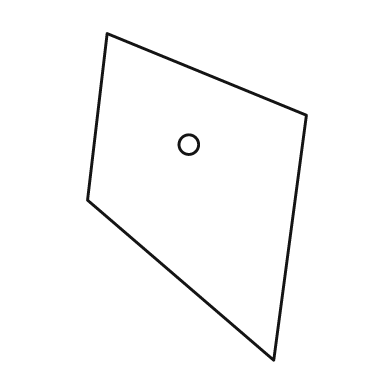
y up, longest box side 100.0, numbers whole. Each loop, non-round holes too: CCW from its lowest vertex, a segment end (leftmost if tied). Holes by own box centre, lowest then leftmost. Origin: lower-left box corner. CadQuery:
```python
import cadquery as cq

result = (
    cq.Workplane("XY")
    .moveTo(57.0, 0.0)
    .lineTo(67.0, 75.0)
    .lineTo(6.0, 100.0)
    .lineTo(0.0, 49.0)
    .close()
    .moveTo(31.0, 66.0)
    .circle(3.0)
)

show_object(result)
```